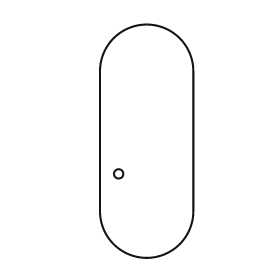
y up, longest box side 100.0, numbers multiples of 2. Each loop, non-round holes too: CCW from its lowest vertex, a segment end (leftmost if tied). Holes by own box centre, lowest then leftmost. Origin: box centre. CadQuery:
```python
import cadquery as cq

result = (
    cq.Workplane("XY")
    .moveTo(-20.0, -30.0)
    .threePointArc((0.0, -50.0), (20.0, -30.0))
    .lineTo(20.0, 30.0)
    .threePointArc((0.0, 50.0), (-20.0, 30.0))
    .close()
    .moveTo(-12.0, -14.0)
    .circle(2.0)
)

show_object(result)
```